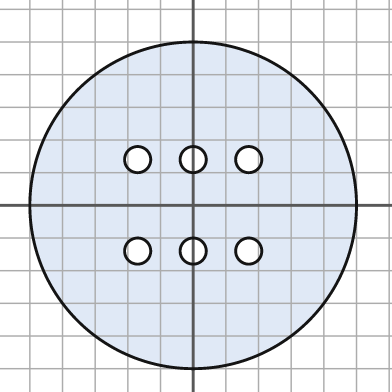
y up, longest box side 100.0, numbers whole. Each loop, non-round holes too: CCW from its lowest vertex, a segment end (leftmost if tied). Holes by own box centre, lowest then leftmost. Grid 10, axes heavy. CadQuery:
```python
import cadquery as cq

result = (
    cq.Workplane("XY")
    .moveTo(0.0, 0.0)
    .circle(50.0)
    .moveTo(-17.0, -14.0)
    .circle(4.0)
    .moveTo(0.0, -14.0)
    .circle(4.0)
    .moveTo(17.0, -14.0)
    .circle(4.0)
    .moveTo(-17.0, 14.0)
    .circle(4.0)
    .moveTo(0.0, 14.0)
    .circle(4.0)
    .moveTo(17.0, 14.0)
    .circle(4.0)
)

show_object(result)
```